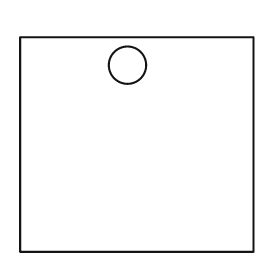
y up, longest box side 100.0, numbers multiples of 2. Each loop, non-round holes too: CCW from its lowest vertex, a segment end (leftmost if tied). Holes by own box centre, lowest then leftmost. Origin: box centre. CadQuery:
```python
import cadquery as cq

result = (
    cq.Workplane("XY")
    .moveTo(-50.0, -46.0)
    .lineTo(50.0, -46.0)
    .lineTo(50.0, 46.0)
    .lineTo(-50.0, 46.0)
    .close()
    .moveTo(-4.0, 34.0)
    .circle(8.0)
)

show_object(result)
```